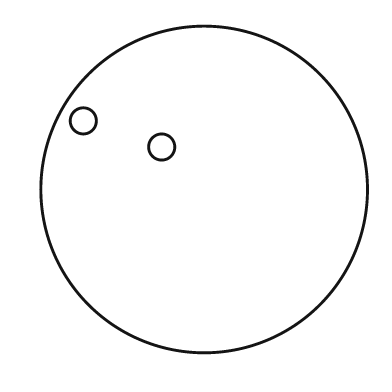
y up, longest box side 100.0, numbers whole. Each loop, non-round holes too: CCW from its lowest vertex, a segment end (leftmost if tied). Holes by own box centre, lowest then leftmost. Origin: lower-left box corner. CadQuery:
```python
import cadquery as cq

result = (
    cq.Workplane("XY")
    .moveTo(50.0, 50.0)
    .circle(50.0)
    .moveTo(37.0, 63.0)
    .circle(4.0)
    .moveTo(13.0, 71.0)
    .circle(4.0)
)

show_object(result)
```